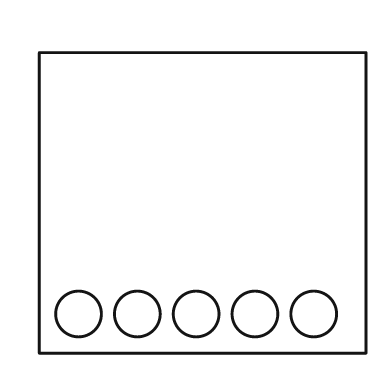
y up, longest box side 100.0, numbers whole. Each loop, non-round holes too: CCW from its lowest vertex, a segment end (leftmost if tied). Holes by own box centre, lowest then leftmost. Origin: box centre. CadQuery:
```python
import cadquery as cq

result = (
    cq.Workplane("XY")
    .moveTo(-50.0, -46.0)
    .lineTo(50.0, -46.0)
    .lineTo(50.0, 46.0)
    .lineTo(-50.0, 46.0)
    .close()
    .moveTo(-38.0, -34.0)
    .circle(7.0)
    .moveTo(-20.0, -34.0)
    .circle(7.0)
    .moveTo(-2.0, -34.0)
    .circle(7.0)
    .moveTo(16.0, -34.0)
    .circle(7.0)
    .moveTo(34.0, -34.0)
    .circle(7.0)
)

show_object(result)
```